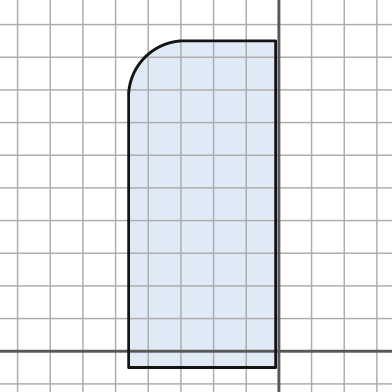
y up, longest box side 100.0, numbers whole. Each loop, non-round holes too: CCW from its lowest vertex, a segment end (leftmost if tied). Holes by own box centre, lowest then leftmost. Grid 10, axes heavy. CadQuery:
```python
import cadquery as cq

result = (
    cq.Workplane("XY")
    .moveTo(-46.0, -5.0)
    .lineTo(-1.0, -5.0)
    .lineTo(-1.0, 95.0)
    .lineTo(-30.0, 95.0)
    .threePointArc((-41.0, 90.0), (-46.0, 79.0))
    .close()
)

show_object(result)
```